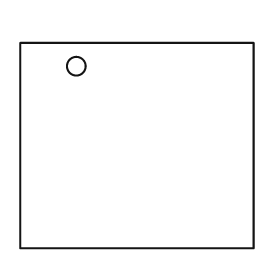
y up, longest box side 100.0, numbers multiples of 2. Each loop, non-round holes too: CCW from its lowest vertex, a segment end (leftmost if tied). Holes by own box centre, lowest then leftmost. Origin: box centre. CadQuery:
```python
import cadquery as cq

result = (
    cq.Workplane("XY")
    .moveTo(-50.0, -44.0)
    .lineTo(50.0, -44.0)
    .lineTo(50.0, 44.0)
    .lineTo(-50.0, 44.0)
    .close()
    .moveTo(-26.0, 34.0)
    .circle(4.0)
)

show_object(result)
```